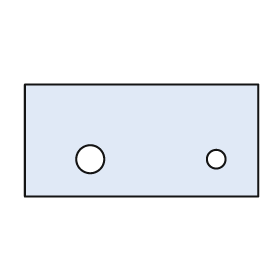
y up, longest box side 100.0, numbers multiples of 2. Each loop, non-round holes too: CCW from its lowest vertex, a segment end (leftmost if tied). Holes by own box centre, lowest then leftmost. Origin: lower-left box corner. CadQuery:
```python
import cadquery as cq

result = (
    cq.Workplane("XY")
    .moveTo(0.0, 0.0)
    .lineTo(100.0, 0.0)
    .lineTo(100.0, 48.0)
    .lineTo(0.0, 48.0)
    .close()
    .moveTo(28.0, 16.0)
    .circle(6.0)
    .moveTo(82.0, 16.0)
    .circle(4.0)
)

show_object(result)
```